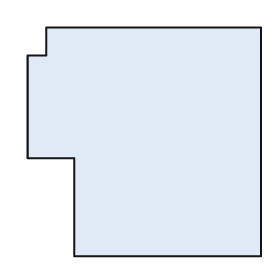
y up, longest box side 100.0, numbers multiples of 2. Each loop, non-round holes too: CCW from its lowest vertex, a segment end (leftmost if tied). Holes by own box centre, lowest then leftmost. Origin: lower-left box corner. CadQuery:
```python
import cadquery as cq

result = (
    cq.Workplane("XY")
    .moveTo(20.0, 0.0)
    .lineTo(100.0, 0.0)
    .lineTo(100.0, 98.0)
    .lineTo(8.0, 98.0)
    .lineTo(8.0, 86.0)
    .lineTo(0.0, 86.0)
    .lineTo(0.0, 42.0)
    .lineTo(20.0, 42.0)
    .close()
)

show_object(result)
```